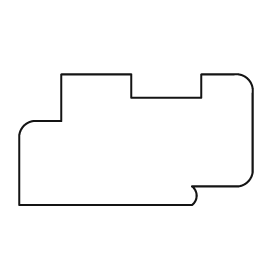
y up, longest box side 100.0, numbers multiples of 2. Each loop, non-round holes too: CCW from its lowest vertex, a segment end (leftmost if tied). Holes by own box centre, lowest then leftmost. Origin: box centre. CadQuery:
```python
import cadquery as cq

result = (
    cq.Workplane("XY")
    .moveTo(-50.0, -28.0)
    .lineTo(24.0, -28.0)
    .threePointArc((26.0, -24.0), (24.0, -20.0))
    .lineTo(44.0, -20.0)
    .threePointArc((48.0, -18.0), (50.0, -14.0))
    .lineTo(50.0, 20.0)
    .threePointArc((48.0, 26.0), (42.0, 28.0))
    .lineTo(28.0, 28.0)
    .lineTo(28.0, 18.0)
    .lineTo(-2.0, 18.0)
    .lineTo(-2.0, 28.0)
    .lineTo(-32.0, 28.0)
    .lineTo(-32.0, 8.0)
    .lineTo(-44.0, 8.0)
    .threePointArc((-48.0, 6.0), (-50.0, 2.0))
    .close()
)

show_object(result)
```